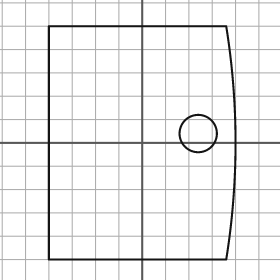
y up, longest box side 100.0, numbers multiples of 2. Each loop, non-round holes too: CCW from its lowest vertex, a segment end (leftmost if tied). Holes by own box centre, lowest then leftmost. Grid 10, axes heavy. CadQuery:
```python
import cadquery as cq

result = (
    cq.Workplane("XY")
    .moveTo(-40.0, -50.0)
    .lineTo(36.0, -50.0)
    .threePointArc((40.0, 0.0), (36.0, 50.0))
    .lineTo(-40.0, 50.0)
    .close()
    .moveTo(24.0, 4.0)
    .circle(8.0)
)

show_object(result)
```